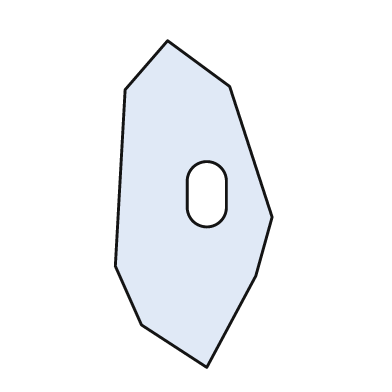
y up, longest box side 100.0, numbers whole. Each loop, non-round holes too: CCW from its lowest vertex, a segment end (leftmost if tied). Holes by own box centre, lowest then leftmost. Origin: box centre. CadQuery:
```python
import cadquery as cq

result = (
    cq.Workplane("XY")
    .moveTo(4.0, -50.0)
    .lineTo(19.0, -22.0)
    .lineTo(24.0, -4.0)
    .lineTo(11.0, 36.0)
    .lineTo(-8.0, 50.0)
    .lineTo(-21.0, 35.0)
    .lineTo(-24.0, -19.0)
    .lineTo(-16.0, -37.0)
    .close()
    .moveTo(-2.0, -1.0)
    .threePointArc((4.0, -7.0), (10.0, -1.0))
    .lineTo(10.0, 7.0)
    .threePointArc((4.0, 13.0), (-2.0, 7.0))
    .close()
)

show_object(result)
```